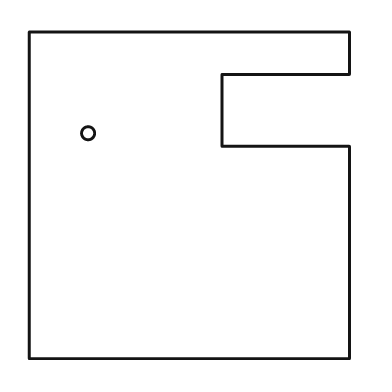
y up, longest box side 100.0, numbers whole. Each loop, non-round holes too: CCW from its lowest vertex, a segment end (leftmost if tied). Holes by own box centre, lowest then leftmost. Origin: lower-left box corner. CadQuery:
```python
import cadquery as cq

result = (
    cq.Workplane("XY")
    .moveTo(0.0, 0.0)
    .lineTo(98.0, 0.0)
    .lineTo(98.0, 65.0)
    .lineTo(59.0, 65.0)
    .lineTo(59.0, 87.0)
    .lineTo(98.0, 87.0)
    .lineTo(98.0, 100.0)
    .lineTo(0.0, 100.0)
    .close()
    .moveTo(18.0, 69.0)
    .circle(2.0)
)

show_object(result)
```